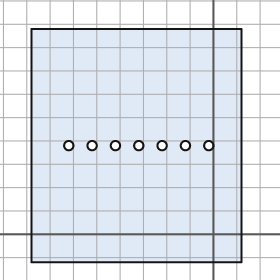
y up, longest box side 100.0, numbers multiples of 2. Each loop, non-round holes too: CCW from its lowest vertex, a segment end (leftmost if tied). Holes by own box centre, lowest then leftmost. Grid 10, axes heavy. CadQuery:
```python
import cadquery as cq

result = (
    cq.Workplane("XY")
    .moveTo(-78.0, -12.0)
    .lineTo(12.0, -12.0)
    .lineTo(12.0, 88.0)
    .lineTo(-78.0, 88.0)
    .close()
    .moveTo(-62.0, 38.0)
    .circle(2.0)
    .moveTo(-52.0, 38.0)
    .circle(2.0)
    .moveTo(-42.0, 38.0)
    .circle(2.0)
    .moveTo(-32.0, 38.0)
    .circle(2.0)
    .moveTo(-22.0, 38.0)
    .circle(2.0)
    .moveTo(-12.0, 38.0)
    .circle(2.0)
    .moveTo(-2.0, 38.0)
    .circle(2.0)
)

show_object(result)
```